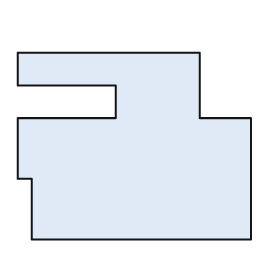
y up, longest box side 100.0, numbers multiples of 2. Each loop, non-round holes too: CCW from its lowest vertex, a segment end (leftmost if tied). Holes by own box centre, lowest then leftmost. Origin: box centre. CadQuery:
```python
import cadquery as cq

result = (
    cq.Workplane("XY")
    .moveTo(-44.0, -40.0)
    .lineTo(50.0, -40.0)
    .lineTo(50.0, 12.0)
    .lineTo(28.0, 12.0)
    .lineTo(28.0, 40.0)
    .lineTo(-50.0, 40.0)
    .lineTo(-50.0, 26.0)
    .lineTo(-8.0, 26.0)
    .lineTo(-8.0, 12.0)
    .lineTo(-50.0, 12.0)
    .lineTo(-50.0, -14.0)
    .lineTo(-44.0, -14.0)
    .close()
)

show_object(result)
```